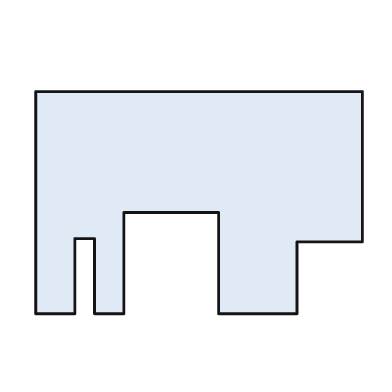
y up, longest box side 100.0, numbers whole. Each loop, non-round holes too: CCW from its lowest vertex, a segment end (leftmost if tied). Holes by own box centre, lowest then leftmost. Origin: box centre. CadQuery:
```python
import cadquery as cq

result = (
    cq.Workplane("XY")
    .moveTo(-50.0, -34.0)
    .lineTo(-38.0, -34.0)
    .lineTo(-38.0, -11.0)
    .lineTo(-32.0, -11.0)
    .lineTo(-32.0, -34.0)
    .lineTo(-23.0, -34.0)
    .lineTo(-23.0, -3.0)
    .lineTo(6.0, -3.0)
    .lineTo(6.0, -34.0)
    .lineTo(30.0, -34.0)
    .lineTo(30.0, -12.0)
    .lineTo(50.0, -12.0)
    .lineTo(50.0, 34.0)
    .lineTo(-50.0, 34.0)
    .close()
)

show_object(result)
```